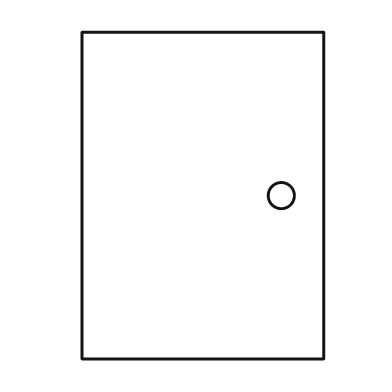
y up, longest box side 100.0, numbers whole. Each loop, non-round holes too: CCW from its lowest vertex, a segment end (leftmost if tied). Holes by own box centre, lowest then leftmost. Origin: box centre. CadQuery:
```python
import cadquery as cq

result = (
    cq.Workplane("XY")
    .moveTo(-37.0, -50.0)
    .lineTo(37.0, -50.0)
    .lineTo(37.0, 50.0)
    .lineTo(-37.0, 50.0)
    .close()
    .moveTo(24.0, 0.0)
    .circle(4.0)
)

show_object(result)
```